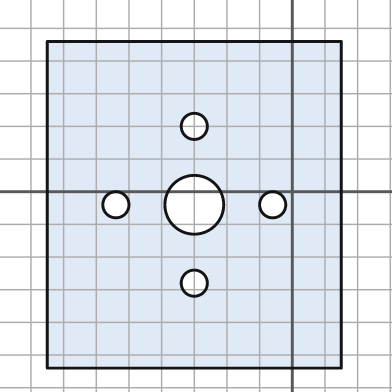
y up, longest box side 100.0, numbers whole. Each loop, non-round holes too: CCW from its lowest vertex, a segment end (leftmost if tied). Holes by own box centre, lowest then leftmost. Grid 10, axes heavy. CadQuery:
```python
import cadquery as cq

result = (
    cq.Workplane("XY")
    .moveTo(-75.0, -54.0)
    .lineTo(15.0, -54.0)
    .lineTo(15.0, 46.0)
    .lineTo(-75.0, 46.0)
    .close()
    .moveTo(-30.0, -28.0)
    .circle(4.0)
    .moveTo(-54.0, -4.0)
    .circle(4.0)
    .moveTo(-30.0, -4.0)
    .circle(9.0)
    .moveTo(-6.0, -4.0)
    .circle(4.0)
    .moveTo(-30.0, 20.0)
    .circle(4.0)
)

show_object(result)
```